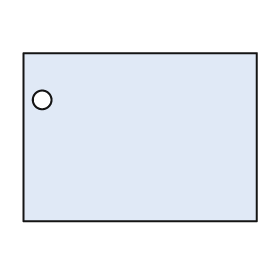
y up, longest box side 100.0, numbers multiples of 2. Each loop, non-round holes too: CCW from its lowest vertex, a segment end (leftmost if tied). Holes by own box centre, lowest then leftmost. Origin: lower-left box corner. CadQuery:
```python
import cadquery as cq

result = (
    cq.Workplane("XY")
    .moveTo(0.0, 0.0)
    .lineTo(100.0, 0.0)
    .lineTo(100.0, 72.0)
    .lineTo(0.0, 72.0)
    .close()
    .moveTo(8.0, 52.0)
    .circle(4.0)
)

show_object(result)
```